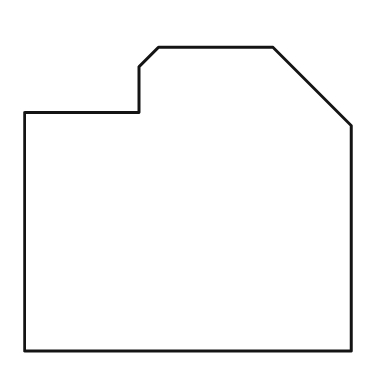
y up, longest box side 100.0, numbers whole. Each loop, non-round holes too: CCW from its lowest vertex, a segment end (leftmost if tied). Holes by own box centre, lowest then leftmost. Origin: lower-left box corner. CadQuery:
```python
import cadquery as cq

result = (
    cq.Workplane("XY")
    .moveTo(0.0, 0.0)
    .lineTo(100.0, 0.0)
    .lineTo(100.0, 69.0)
    .lineTo(76.0, 93.0)
    .lineTo(41.0, 93.0)
    .lineTo(35.0, 87.0)
    .lineTo(35.0, 73.0)
    .lineTo(0.0, 73.0)
    .close()
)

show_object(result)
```